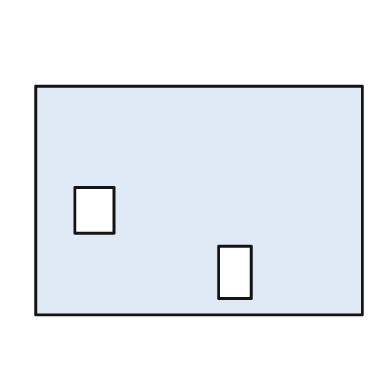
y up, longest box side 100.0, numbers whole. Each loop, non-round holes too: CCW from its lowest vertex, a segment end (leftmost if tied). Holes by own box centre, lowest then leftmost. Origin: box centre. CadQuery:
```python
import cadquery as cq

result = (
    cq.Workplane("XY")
    .moveTo(-50.0, -35.0)
    .lineTo(50.0, -35.0)
    .lineTo(50.0, 35.0)
    .lineTo(-50.0, 35.0)
    .close()
    .moveTo(6.0, -30.0)
    .lineTo(16.0, -30.0)
    .lineTo(16.0, -14.0)
    .lineTo(6.0, -14.0)
    .close()
    .moveTo(-38.0, -10.0)
    .lineTo(-26.0, -10.0)
    .lineTo(-26.0, 4.0)
    .lineTo(-38.0, 4.0)
    .close()
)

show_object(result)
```